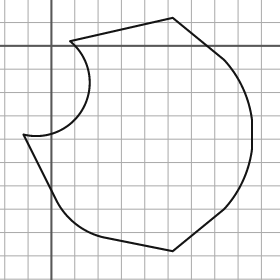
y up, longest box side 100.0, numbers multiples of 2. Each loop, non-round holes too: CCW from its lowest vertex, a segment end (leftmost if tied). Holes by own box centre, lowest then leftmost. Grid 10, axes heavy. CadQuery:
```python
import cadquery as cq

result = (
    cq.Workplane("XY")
    .moveTo(52.0, -88.0)
    .lineTo(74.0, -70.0)
    .threePointArc((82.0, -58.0), (86.0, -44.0))
    .lineTo(86.0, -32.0)
    .threePointArc((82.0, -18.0), (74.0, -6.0))
    .lineTo(52.0, 12.0)
    .lineTo(8.0, 2.0)
    .threePointArc((14.0, -26.0), (-12.0, -38.0))
    .lineTo(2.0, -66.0)
    .threePointArc((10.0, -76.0), (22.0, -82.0))
    .close()
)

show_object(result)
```